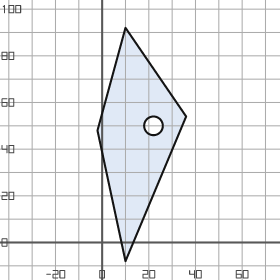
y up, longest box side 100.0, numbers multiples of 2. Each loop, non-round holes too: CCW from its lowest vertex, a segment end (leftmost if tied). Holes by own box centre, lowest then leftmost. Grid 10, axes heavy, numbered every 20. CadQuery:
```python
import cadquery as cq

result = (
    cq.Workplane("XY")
    .moveTo(10.0, -8.0)
    .lineTo(36.0, 54.0)
    .lineTo(10.0, 92.0)
    .lineTo(-2.0, 48.0)
    .close()
    .moveTo(22.0, 50.0)
    .circle(4.0)
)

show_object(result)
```